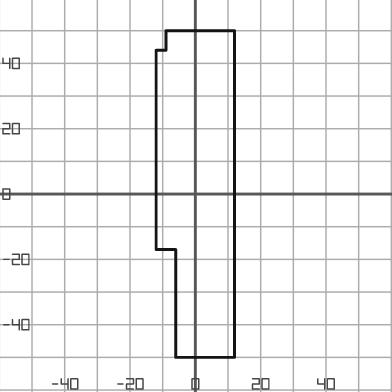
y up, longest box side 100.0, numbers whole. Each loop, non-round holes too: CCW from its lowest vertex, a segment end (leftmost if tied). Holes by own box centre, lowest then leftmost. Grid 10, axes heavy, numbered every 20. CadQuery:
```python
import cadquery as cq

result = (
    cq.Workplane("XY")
    .moveTo(-6.0, -50.0)
    .lineTo(12.0, -50.0)
    .lineTo(12.0, 50.0)
    .lineTo(-9.0, 50.0)
    .lineTo(-9.0, 44.0)
    .lineTo(-12.0, 44.0)
    .lineTo(-12.0, -17.0)
    .lineTo(-6.0, -17.0)
    .close()
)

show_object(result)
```